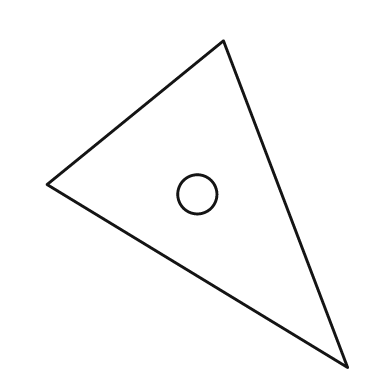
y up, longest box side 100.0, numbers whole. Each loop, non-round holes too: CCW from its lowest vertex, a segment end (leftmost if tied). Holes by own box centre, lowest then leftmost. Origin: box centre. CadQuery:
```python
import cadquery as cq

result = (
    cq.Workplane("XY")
    .moveTo(46.0, -50.0)
    .lineTo(8.0, 50.0)
    .lineTo(-46.0, 6.0)
    .close()
    .moveTo(0.0, 3.0)
    .circle(6.0)
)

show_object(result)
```